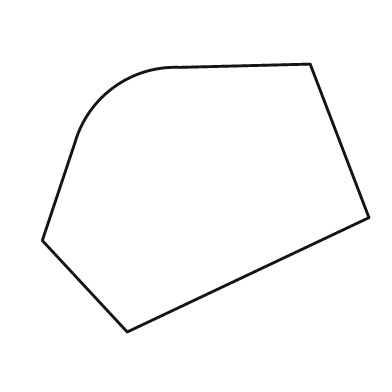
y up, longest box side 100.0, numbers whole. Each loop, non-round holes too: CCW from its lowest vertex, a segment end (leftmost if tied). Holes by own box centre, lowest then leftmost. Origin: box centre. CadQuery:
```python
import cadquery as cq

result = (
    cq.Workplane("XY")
    .moveTo(-24.0, -41.0)
    .lineTo(50.0, -6.0)
    .lineTo(32.0, 41.0)
    .lineTo(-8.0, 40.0)
    .threePointArc((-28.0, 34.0), (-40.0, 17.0))
    .lineTo(-50.0, -13.0)
    .close()
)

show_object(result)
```